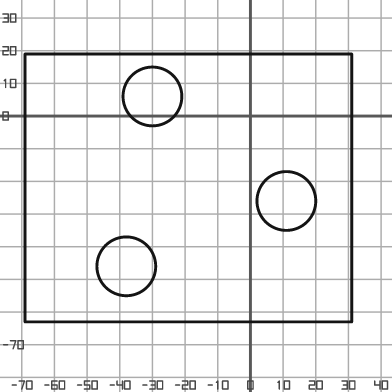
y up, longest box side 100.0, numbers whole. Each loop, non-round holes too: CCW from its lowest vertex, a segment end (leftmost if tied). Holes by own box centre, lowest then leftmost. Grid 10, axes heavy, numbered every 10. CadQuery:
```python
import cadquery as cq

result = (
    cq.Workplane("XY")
    .moveTo(-69.0, -63.0)
    .lineTo(31.0, -63.0)
    .lineTo(31.0, 19.0)
    .lineTo(-69.0, 19.0)
    .close()
    .moveTo(-38.0, -46.0)
    .circle(9.0)
    .moveTo(11.0, -26.0)
    .circle(9.0)
    .moveTo(-30.0, 6.0)
    .circle(9.0)
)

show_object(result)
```